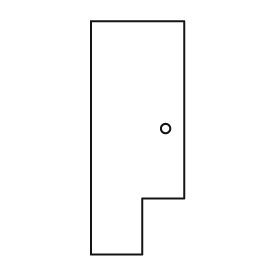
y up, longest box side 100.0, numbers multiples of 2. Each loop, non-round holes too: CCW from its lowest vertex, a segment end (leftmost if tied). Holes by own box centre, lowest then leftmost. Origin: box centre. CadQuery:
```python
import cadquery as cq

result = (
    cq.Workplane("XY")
    .moveTo(-20.0, -50.0)
    .lineTo(2.0, -50.0)
    .lineTo(2.0, -26.0)
    .lineTo(20.0, -26.0)
    .lineTo(20.0, 50.0)
    .lineTo(-20.0, 50.0)
    .close()
    .moveTo(12.0, 4.0)
    .circle(2.0)
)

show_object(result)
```